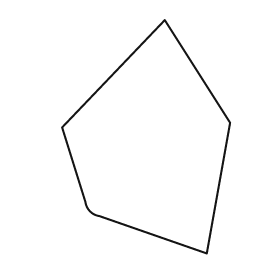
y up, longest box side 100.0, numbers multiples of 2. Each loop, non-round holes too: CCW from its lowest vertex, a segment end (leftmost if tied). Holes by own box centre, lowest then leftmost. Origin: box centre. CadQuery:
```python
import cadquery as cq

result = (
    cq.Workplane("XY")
    .moveTo(26.0, -50.0)
    .lineTo(36.0, 6.0)
    .lineTo(8.0, 50.0)
    .lineTo(-36.0, 4.0)
    .lineTo(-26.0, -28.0)
    .threePointArc((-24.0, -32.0), (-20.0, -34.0))
    .close()
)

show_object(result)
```